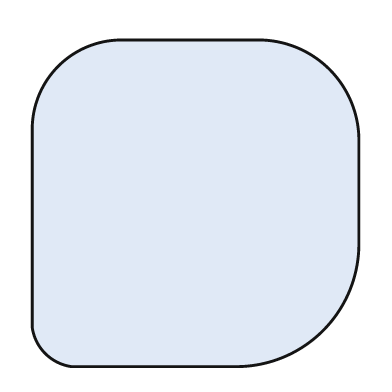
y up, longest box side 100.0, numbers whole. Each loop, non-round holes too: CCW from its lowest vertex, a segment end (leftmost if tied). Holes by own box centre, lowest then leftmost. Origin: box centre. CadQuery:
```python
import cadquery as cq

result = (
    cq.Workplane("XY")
    .moveTo(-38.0, -50.0)
    .lineTo(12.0, -50.0)
    .threePointArc((39.0, -39.0), (50.0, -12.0))
    .lineTo(50.0, 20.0)
    .threePointArc((41.0, 41.0), (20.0, 50.0))
    .lineTo(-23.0, 50.0)
    .threePointArc((-42.0, 42.0), (-50.0, 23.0))
    .lineTo(-50.0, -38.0)
    .threePointArc((-46.0, -46.0), (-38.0, -50.0))
    .close()
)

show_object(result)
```